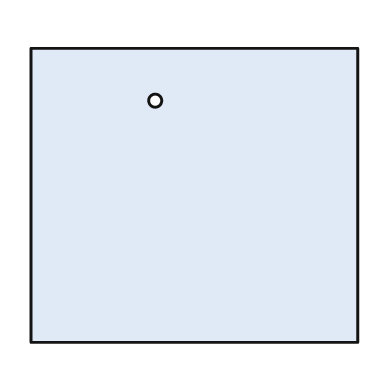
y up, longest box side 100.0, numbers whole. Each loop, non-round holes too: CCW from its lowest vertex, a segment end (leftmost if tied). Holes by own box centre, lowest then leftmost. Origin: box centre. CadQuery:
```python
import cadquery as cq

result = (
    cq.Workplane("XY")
    .moveTo(-50.0, -45.0)
    .lineTo(50.0, -45.0)
    .lineTo(50.0, 45.0)
    .lineTo(-50.0, 45.0)
    .close()
    .moveTo(-12.0, 29.0)
    .circle(2.0)
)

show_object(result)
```